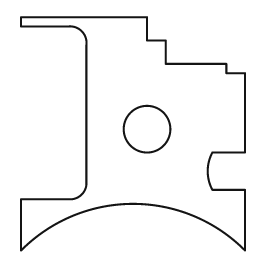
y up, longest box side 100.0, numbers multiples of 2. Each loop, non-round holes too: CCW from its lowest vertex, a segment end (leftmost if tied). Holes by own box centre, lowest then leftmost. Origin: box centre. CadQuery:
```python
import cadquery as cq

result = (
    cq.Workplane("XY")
    .moveTo(-48.0, -50.0)
    .threePointArc((0.0, -30.0), (48.0, -50.0))
    .lineTo(48.0, -24.0)
    .lineTo(34.0, -24.0)
    .threePointArc((32.0, -16.0), (34.0, -8.0))
    .lineTo(48.0, -8.0)
    .lineTo(48.0, 26.0)
    .lineTo(40.0, 26.0)
    .lineTo(40.0, 30.0)
    .lineTo(14.0, 30.0)
    .lineTo(14.0, 40.0)
    .lineTo(6.0, 40.0)
    .lineTo(6.0, 50.0)
    .lineTo(-48.0, 50.0)
    .lineTo(-48.0, 46.0)
    .lineTo(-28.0, 46.0)
    .threePointArc((-22.0, 44.0), (-20.0, 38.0))
    .lineTo(-20.0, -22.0)
    .threePointArc((-22.0, -26.0), (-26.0, -28.0))
    .lineTo(-48.0, -28.0)
    .close()
    .moveTo(6.0, 2.0)
    .circle(10.0)
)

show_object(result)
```